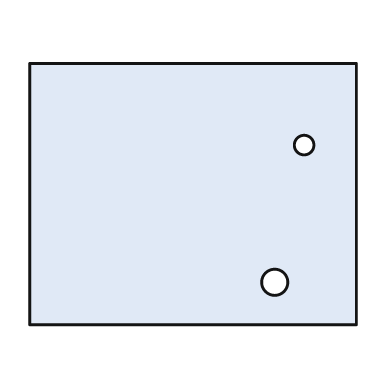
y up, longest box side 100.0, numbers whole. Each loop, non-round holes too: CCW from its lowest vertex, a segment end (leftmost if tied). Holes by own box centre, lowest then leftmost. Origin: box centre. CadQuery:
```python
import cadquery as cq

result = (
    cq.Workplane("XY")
    .moveTo(-50.0, -40.0)
    .lineTo(50.0, -40.0)
    .lineTo(50.0, 40.0)
    .lineTo(-50.0, 40.0)
    .close()
    .moveTo(25.0, -27.0)
    .circle(4.0)
    .moveTo(34.0, 15.0)
    .circle(3.0)
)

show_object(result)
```